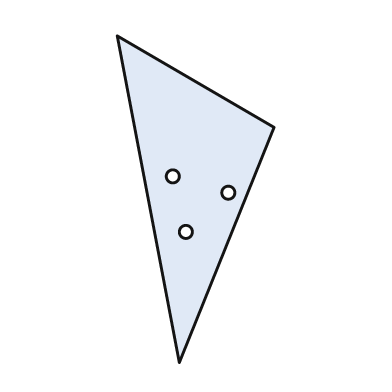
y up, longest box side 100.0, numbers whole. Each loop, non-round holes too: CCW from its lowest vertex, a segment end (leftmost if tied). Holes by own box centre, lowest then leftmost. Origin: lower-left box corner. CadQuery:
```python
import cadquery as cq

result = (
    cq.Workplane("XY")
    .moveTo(19.0, 0.0)
    .lineTo(48.0, 72.0)
    .lineTo(0.0, 100.0)
    .close()
    .moveTo(21.0, 40.0)
    .circle(2.0)
    .moveTo(34.0, 52.0)
    .circle(2.0)
    .moveTo(17.0, 57.0)
    .circle(2.0)
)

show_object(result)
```